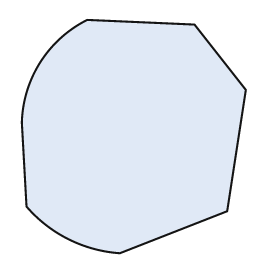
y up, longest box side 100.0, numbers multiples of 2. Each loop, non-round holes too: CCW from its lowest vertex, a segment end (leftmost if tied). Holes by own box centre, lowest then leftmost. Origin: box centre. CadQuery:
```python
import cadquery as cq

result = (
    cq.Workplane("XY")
    .moveTo(-6.0, -50.0)
    .lineTo(40.0, -32.0)
    .lineTo(48.0, 20.0)
    .lineTo(26.0, 48.0)
    .lineTo(-20.0, 50.0)
    .threePointArc((-40.0, 32.0), (-48.0, 6.0))
    .lineTo(-46.0, -30.0)
    .threePointArc((-28.0, -44.0), (-6.0, -50.0))
    .close()
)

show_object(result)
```